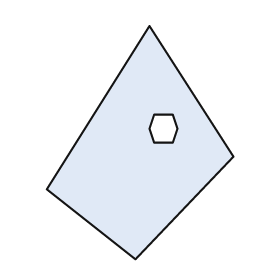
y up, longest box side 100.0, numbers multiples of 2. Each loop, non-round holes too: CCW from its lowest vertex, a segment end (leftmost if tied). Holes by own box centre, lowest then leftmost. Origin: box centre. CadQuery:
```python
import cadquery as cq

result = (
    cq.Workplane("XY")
    .moveTo(-2.0, -50.0)
    .lineTo(40.0, -6.0)
    .lineTo(4.0, 50.0)
    .lineTo(-40.0, -20.0)
    .close()
    .moveTo(6.0, 0.0)
    .lineTo(14.0, 0.0)
    .lineTo(16.0, 6.0)
    .lineTo(14.0, 12.0)
    .lineTo(6.0, 12.0)
    .lineTo(4.0, 6.0)
    .close()
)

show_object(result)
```